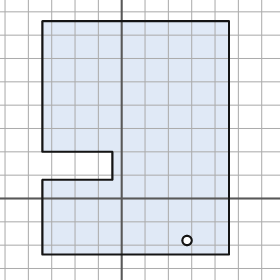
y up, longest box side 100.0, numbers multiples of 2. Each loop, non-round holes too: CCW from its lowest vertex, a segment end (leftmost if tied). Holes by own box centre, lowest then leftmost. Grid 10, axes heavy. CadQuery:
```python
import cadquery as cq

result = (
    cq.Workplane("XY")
    .moveTo(-34.0, -24.0)
    .lineTo(46.0, -24.0)
    .lineTo(46.0, 76.0)
    .lineTo(-34.0, 76.0)
    .lineTo(-34.0, 20.0)
    .lineTo(-4.0, 20.0)
    .lineTo(-4.0, 8.0)
    .lineTo(-34.0, 8.0)
    .close()
    .moveTo(28.0, -18.0)
    .circle(2.0)
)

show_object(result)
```